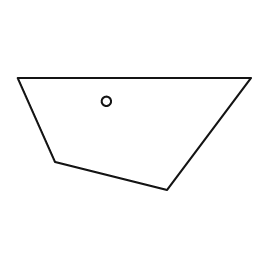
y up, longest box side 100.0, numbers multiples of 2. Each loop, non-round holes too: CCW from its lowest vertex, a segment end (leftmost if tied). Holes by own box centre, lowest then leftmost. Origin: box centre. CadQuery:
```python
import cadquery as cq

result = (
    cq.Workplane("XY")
    .moveTo(14.0, -24.0)
    .lineTo(50.0, 24.0)
    .lineTo(-50.0, 24.0)
    .lineTo(-34.0, -12.0)
    .close()
    .moveTo(-12.0, 14.0)
    .circle(2.0)
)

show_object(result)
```